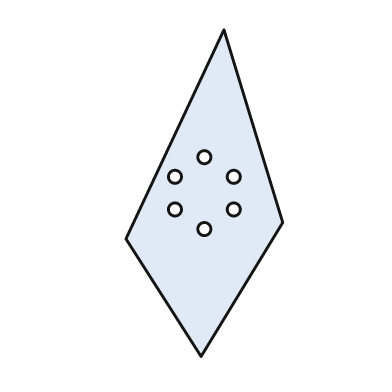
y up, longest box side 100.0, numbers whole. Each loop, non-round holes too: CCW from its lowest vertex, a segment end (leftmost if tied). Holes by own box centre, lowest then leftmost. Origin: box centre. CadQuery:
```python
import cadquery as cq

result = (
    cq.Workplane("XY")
    .moveTo(-1.0, -50.0)
    .lineTo(24.0, -9.0)
    .lineTo(6.0, 50.0)
    .lineTo(-24.0, -14.0)
    .close()
    .moveTo(0.0, -11.0)
    .circle(2.0)
    .moveTo(-9.0, -5.0)
    .circle(2.0)
    .moveTo(9.0, -5.0)
    .circle(2.0)
    .moveTo(-9.0, 5.0)
    .circle(2.0)
    .moveTo(9.0, 5.0)
    .circle(2.0)
    .moveTo(0.0, 11.0)
    .circle(2.0)
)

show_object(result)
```